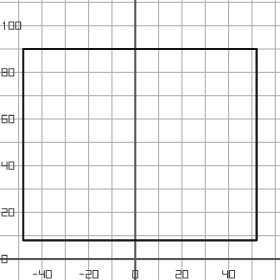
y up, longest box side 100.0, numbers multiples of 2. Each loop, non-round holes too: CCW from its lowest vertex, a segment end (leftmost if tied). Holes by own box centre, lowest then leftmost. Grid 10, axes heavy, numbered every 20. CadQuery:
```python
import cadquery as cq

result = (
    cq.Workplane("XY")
    .moveTo(-48.0, 8.0)
    .lineTo(52.0, 8.0)
    .lineTo(52.0, 90.0)
    .lineTo(-48.0, 90.0)
    .close()
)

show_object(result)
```